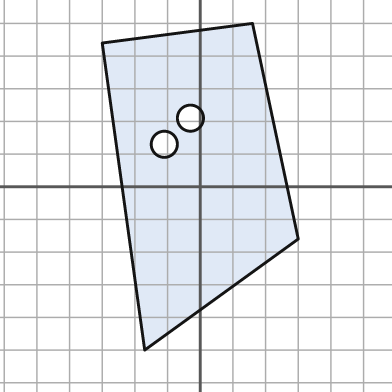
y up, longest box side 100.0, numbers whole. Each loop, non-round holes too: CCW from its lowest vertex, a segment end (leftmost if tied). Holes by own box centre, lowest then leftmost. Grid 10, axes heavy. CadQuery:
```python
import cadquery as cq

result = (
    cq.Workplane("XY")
    .moveTo(-17.0, -50.0)
    .lineTo(30.0, -16.0)
    .lineTo(16.0, 50.0)
    .lineTo(-30.0, 44.0)
    .close()
    .moveTo(-11.0, 13.0)
    .circle(4.0)
    .moveTo(-3.0, 21.0)
    .circle(4.0)
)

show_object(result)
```